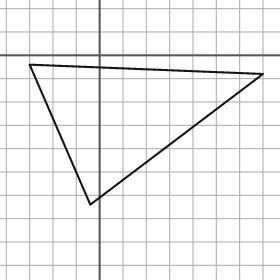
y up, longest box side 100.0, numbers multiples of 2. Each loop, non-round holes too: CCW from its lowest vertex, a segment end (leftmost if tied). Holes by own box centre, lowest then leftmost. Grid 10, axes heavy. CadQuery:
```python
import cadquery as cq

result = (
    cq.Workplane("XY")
    .moveTo(-4.0, -64.0)
    .lineTo(70.0, -8.0)
    .lineTo(-30.0, -4.0)
    .close()
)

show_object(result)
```